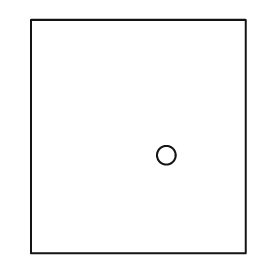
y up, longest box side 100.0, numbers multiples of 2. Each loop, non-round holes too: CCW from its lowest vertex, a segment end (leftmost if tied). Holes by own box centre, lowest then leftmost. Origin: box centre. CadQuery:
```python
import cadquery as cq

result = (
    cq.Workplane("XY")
    .moveTo(-46.0, -50.0)
    .lineTo(46.0, -50.0)
    .lineTo(46.0, 50.0)
    .lineTo(-46.0, 50.0)
    .close()
    .moveTo(12.0, -8.0)
    .circle(4.0)
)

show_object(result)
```